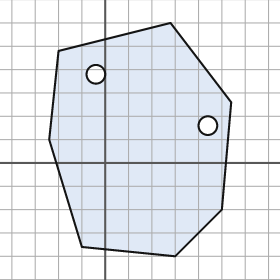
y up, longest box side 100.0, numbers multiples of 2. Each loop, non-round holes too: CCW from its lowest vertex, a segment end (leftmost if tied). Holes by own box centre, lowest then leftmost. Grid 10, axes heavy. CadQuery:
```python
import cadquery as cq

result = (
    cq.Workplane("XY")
    .moveTo(30.0, -40.0)
    .lineTo(50.0, -20.0)
    .lineTo(54.0, 26.0)
    .lineTo(28.0, 60.0)
    .lineTo(-20.0, 48.0)
    .lineTo(-24.0, 10.0)
    .lineTo(-10.0, -36.0)
    .close()
    .moveTo(44.0, 16.0)
    .circle(4.0)
    .moveTo(-4.0, 38.0)
    .circle(4.0)
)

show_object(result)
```